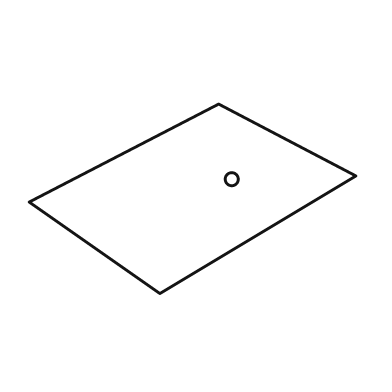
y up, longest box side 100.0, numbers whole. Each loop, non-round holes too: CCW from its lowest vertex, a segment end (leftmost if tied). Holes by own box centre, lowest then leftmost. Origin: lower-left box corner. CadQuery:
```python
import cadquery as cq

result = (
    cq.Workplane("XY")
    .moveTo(40.0, 0.0)
    .lineTo(100.0, 36.0)
    .lineTo(58.0, 58.0)
    .lineTo(0.0, 28.0)
    .close()
    .moveTo(62.0, 35.0)
    .circle(2.0)
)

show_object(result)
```